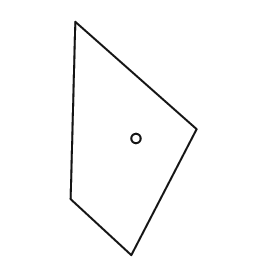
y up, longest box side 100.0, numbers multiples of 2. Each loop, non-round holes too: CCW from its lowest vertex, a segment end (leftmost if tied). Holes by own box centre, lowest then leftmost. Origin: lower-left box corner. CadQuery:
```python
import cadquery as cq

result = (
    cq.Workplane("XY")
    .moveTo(26.0, 0.0)
    .lineTo(54.0, 54.0)
    .lineTo(2.0, 100.0)
    .lineTo(0.0, 24.0)
    .close()
    .moveTo(28.0, 50.0)
    .circle(2.0)
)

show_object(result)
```